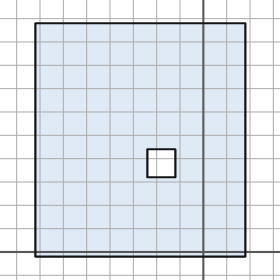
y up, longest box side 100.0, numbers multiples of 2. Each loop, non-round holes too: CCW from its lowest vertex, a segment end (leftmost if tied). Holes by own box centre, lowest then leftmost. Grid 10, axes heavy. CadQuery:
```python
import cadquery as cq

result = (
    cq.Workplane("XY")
    .moveTo(-72.0, -2.0)
    .lineTo(18.0, -2.0)
    .lineTo(18.0, 98.0)
    .lineTo(-72.0, 98.0)
    .close()
    .moveTo(-24.0, 32.0)
    .lineTo(-12.0, 32.0)
    .lineTo(-12.0, 44.0)
    .lineTo(-24.0, 44.0)
    .close()
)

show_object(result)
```